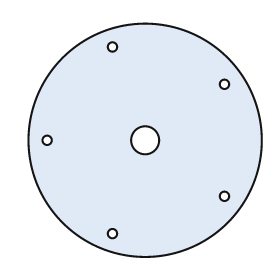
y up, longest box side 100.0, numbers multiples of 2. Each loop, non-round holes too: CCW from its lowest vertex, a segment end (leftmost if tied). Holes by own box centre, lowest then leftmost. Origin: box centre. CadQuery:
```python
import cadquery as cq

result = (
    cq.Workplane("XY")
    .moveTo(0.0, 0.0)
    .circle(50.0)
    .moveTo(-14.0, -40.0)
    .circle(2.0)
    .moveTo(34.0, -24.0)
    .circle(2.0)
    .moveTo(-42.0, 0.0)
    .circle(2.0)
    .moveTo(0.0, 0.0)
    .circle(6.0)
    .moveTo(34.0, 24.0)
    .circle(2.0)
    .moveTo(-14.0, 40.0)
    .circle(2.0)
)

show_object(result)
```